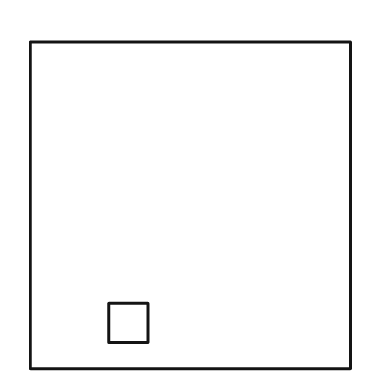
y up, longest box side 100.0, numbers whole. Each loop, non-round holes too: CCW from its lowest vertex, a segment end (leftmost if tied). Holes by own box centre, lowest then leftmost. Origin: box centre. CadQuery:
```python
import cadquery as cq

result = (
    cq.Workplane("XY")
    .moveTo(-49.0, -50.0)
    .lineTo(49.0, -50.0)
    .lineTo(49.0, 50.0)
    .lineTo(-49.0, 50.0)
    .close()
    .moveTo(-25.0, -42.0)
    .lineTo(-13.0, -42.0)
    .lineTo(-13.0, -30.0)
    .lineTo(-25.0, -30.0)
    .close()
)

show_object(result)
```